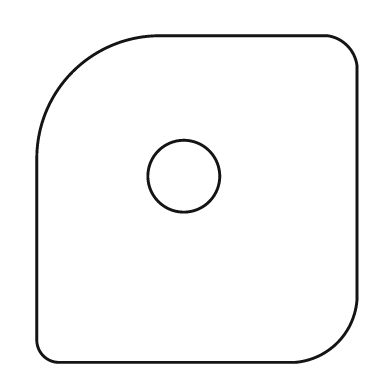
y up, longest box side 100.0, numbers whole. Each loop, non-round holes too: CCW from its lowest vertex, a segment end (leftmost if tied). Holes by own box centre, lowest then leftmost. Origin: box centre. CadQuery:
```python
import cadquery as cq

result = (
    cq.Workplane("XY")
    .moveTo(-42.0, -50.0)
    .lineTo(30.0, -50.0)
    .threePointArc((43.0, -44.0), (49.0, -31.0))
    .lineTo(49.0, 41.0)
    .threePointArc((46.0, 47.0), (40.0, 50.0))
    .lineTo(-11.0, 50.0)
    .threePointArc((-38.0, 39.0), (-49.0, 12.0))
    .lineTo(-49.0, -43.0)
    .threePointArc((-47.0, -48.0), (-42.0, -50.0))
    .close()
    .moveTo(-4.0, 7.0)
    .circle(11.0)
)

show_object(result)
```